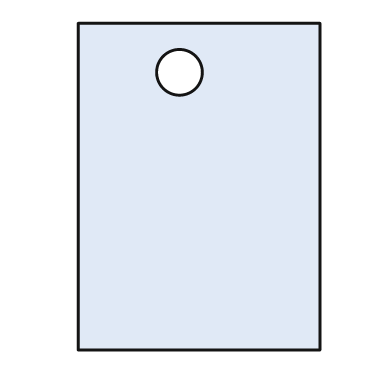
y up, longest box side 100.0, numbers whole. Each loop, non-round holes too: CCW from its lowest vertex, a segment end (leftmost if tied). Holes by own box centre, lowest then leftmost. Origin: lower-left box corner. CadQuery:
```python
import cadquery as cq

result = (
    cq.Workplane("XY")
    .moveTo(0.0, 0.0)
    .lineTo(74.0, 0.0)
    .lineTo(74.0, 100.0)
    .lineTo(0.0, 100.0)
    .close()
    .moveTo(31.0, 85.0)
    .circle(7.0)
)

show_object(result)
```